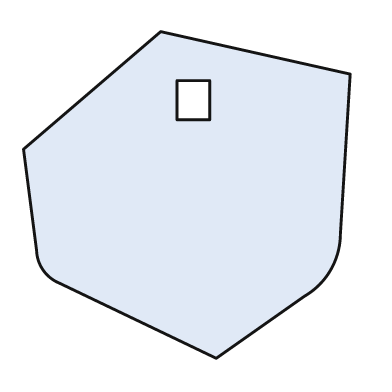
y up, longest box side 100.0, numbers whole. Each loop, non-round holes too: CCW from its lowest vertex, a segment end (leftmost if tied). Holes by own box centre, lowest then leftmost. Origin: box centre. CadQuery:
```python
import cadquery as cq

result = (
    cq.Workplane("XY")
    .moveTo(9.0, -50.0)
    .lineTo(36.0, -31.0)
    .threePointArc((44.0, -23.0), (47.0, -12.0))
    .lineTo(50.0, 37.0)
    .lineTo(-8.0, 50.0)
    .lineTo(-50.0, 14.0)
    .lineTo(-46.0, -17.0)
    .threePointArc((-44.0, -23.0), (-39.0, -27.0))
    .close()
    .moveTo(-3.0, 23.0)
    .lineTo(7.0, 23.0)
    .lineTo(7.0, 35.0)
    .lineTo(-3.0, 35.0)
    .close()
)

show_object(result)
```